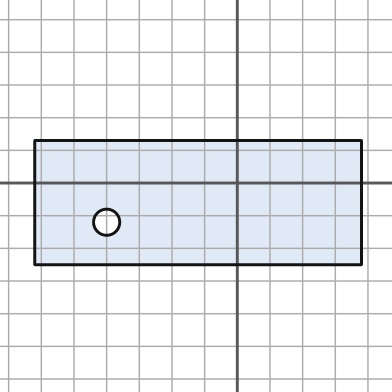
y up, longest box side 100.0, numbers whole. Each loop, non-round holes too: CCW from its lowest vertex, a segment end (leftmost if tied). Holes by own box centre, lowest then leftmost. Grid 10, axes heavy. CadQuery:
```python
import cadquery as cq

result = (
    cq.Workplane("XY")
    .moveTo(-62.0, -25.0)
    .lineTo(38.0, -25.0)
    .lineTo(38.0, 13.0)
    .lineTo(-62.0, 13.0)
    .close()
    .moveTo(-40.0, -12.0)
    .circle(4.0)
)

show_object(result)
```